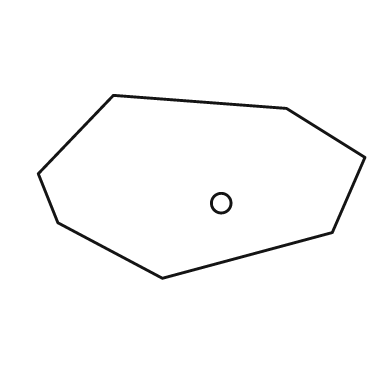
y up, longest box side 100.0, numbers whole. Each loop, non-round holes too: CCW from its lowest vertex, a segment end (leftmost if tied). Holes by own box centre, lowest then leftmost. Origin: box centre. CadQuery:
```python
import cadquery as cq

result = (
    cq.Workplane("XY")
    .moveTo(-12.0, -28.0)
    .lineTo(40.0, -14.0)
    .lineTo(50.0, 9.0)
    .lineTo(26.0, 24.0)
    .lineTo(-27.0, 28.0)
    .lineTo(-50.0, 4.0)
    .lineTo(-44.0, -11.0)
    .close()
    .moveTo(6.0, -5.0)
    .circle(3.0)
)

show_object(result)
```